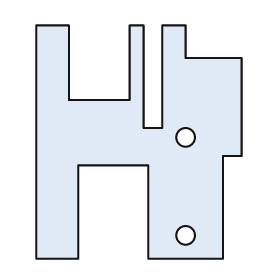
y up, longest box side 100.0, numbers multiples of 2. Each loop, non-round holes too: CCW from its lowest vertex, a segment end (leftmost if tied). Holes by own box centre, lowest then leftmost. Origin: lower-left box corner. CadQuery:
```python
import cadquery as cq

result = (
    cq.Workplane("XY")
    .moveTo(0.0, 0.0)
    .lineTo(18.0, 0.0)
    .lineTo(18.0, 40.0)
    .lineTo(48.0, 40.0)
    .lineTo(48.0, 0.0)
    .lineTo(80.0, 0.0)
    .lineTo(80.0, 44.0)
    .lineTo(88.0, 44.0)
    .lineTo(88.0, 86.0)
    .lineTo(64.0, 86.0)
    .lineTo(64.0, 100.0)
    .lineTo(54.0, 100.0)
    .lineTo(54.0, 56.0)
    .lineTo(46.0, 56.0)
    .lineTo(46.0, 100.0)
    .lineTo(40.0, 100.0)
    .lineTo(40.0, 68.0)
    .lineTo(14.0, 68.0)
    .lineTo(14.0, 100.0)
    .lineTo(0.0, 100.0)
    .close()
    .moveTo(64.0, 10.0)
    .circle(4.0)
    .moveTo(64.0, 52.0)
    .circle(4.0)
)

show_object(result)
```